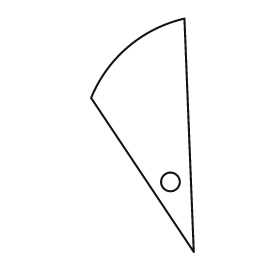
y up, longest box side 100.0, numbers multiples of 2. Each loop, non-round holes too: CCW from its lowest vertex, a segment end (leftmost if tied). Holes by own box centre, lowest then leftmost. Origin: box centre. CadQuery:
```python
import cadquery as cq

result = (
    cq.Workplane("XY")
    .moveTo(22.0, -50.0)
    .lineTo(18.0, 50.0)
    .threePointArc((-6.0, 38.0), (-22.0, 16.0))
    .close()
    .moveTo(12.0, -20.0)
    .circle(4.0)
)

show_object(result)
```